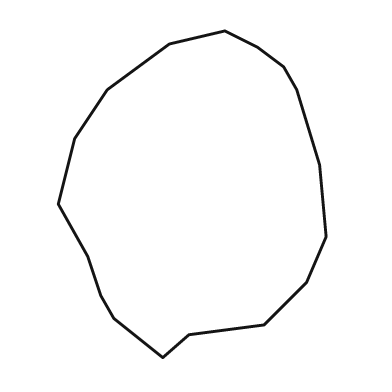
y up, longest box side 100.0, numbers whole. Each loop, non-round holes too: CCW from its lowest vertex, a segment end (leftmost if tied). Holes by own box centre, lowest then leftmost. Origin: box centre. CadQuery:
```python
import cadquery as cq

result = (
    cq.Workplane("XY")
    .moveTo(-9.0, -50.0)
    .lineTo(-1.0, -43.0)
    .lineTo(22.0, -40.0)
    .lineTo(35.0, -27.0)
    .lineTo(41.0, -13.0)
    .lineTo(39.0, 9.0)
    .lineTo(32.0, 32.0)
    .lineTo(28.0, 39.0)
    .lineTo(20.0, 45.0)
    .lineTo(10.0, 50.0)
    .lineTo(-7.0, 46.0)
    .lineTo(-26.0, 32.0)
    .lineTo(-36.0, 17.0)
    .lineTo(-41.0, -3.0)
    .lineTo(-32.0, -19.0)
    .lineTo(-28.0, -31.0)
    .lineTo(-24.0, -38.0)
    .close()
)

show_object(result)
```